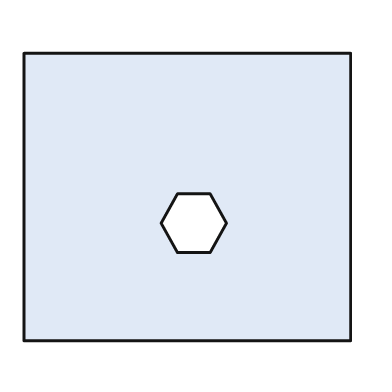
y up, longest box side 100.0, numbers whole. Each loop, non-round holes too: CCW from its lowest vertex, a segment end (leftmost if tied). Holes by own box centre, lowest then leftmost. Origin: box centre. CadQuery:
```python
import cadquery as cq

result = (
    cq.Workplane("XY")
    .moveTo(-50.0, -44.0)
    .lineTo(50.0, -44.0)
    .lineTo(50.0, 44.0)
    .lineTo(-50.0, 44.0)
    .close()
    .moveTo(-3.0, -17.0)
    .lineTo(7.0, -17.0)
    .lineTo(12.0, -8.0)
    .lineTo(7.0, 1.0)
    .lineTo(-3.0, 1.0)
    .lineTo(-8.0, -8.0)
    .close()
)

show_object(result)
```